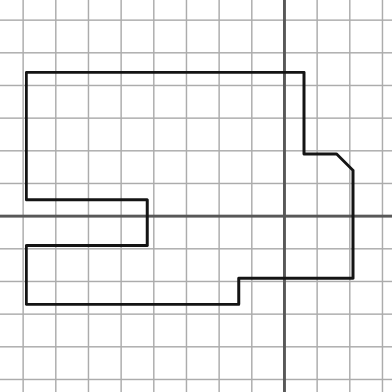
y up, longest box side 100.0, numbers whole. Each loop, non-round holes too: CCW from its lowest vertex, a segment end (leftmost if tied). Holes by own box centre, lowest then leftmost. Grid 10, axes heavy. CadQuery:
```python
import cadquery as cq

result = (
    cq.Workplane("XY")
    .moveTo(-79.0, -27.0)
    .lineTo(-14.0, -27.0)
    .lineTo(-14.0, -19.0)
    .lineTo(21.0, -19.0)
    .lineTo(21.0, 14.0)
    .lineTo(16.0, 19.0)
    .lineTo(6.0, 19.0)
    .lineTo(6.0, 44.0)
    .lineTo(-79.0, 44.0)
    .lineTo(-79.0, 5.0)
    .lineTo(-42.0, 5.0)
    .lineTo(-42.0, -9.0)
    .lineTo(-79.0, -9.0)
    .close()
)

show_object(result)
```